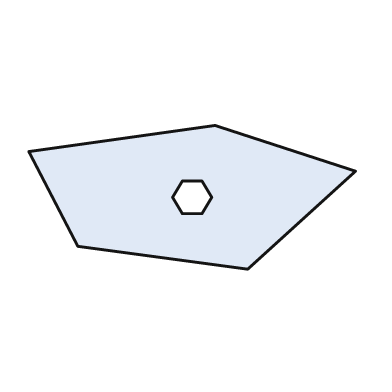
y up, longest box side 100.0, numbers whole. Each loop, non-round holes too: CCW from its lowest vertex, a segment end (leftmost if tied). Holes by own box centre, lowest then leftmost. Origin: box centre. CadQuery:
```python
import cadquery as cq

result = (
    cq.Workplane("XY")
    .moveTo(17.0, -22.0)
    .lineTo(50.0, 8.0)
    .lineTo(7.0, 22.0)
    .lineTo(-50.0, 14.0)
    .lineTo(-35.0, -15.0)
    .close()
    .moveTo(-3.0, -5.0)
    .lineTo(3.0, -5.0)
    .lineTo(6.0, 0.0)
    .lineTo(3.0, 5.0)
    .lineTo(-3.0, 5.0)
    .lineTo(-6.0, 0.0)
    .close()
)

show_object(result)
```